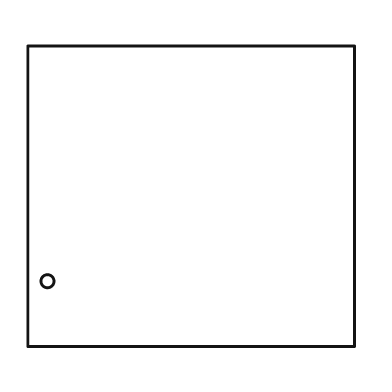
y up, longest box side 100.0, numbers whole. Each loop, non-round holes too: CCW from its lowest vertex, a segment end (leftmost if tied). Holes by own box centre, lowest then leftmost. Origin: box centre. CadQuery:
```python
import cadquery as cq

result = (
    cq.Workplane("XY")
    .moveTo(-50.0, -46.0)
    .lineTo(50.0, -46.0)
    .lineTo(50.0, 46.0)
    .lineTo(-50.0, 46.0)
    .close()
    .moveTo(-44.0, -26.0)
    .circle(2.0)
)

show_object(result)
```